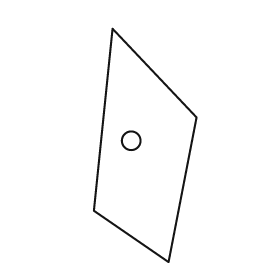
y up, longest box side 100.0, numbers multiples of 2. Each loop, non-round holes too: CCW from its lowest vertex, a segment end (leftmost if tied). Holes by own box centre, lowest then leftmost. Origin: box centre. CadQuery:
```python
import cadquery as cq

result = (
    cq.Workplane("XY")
    .moveTo(10.0, -50.0)
    .lineTo(22.0, 12.0)
    .lineTo(-14.0, 50.0)
    .lineTo(-22.0, -28.0)
    .close()
    .moveTo(-6.0, 2.0)
    .circle(4.0)
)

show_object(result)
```